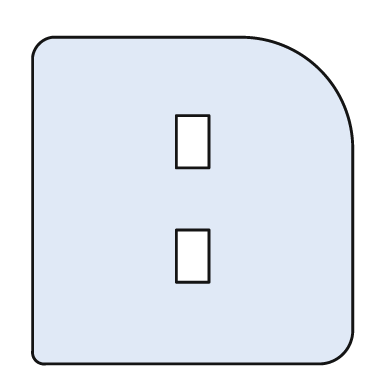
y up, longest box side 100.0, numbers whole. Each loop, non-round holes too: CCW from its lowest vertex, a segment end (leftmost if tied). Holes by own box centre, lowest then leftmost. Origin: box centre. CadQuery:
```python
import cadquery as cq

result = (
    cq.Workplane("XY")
    .moveTo(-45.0, -50.0)
    .lineTo(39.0, -50.0)
    .threePointArc((46.0, -47.0), (49.0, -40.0))
    .lineTo(49.0, 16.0)
    .threePointArc((39.0, 40.0), (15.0, 50.0))
    .lineTo(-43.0, 50.0)
    .threePointArc((-47.0, 48.0), (-49.0, 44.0))
    .lineTo(-49.0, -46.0)
    .threePointArc((-48.0, -49.0), (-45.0, -50.0))
    .close()
    .moveTo(-5.0, -25.0)
    .lineTo(5.0, -25.0)
    .lineTo(5.0, -9.0)
    .lineTo(-5.0, -9.0)
    .close()
    .moveTo(-5.0, 10.0)
    .lineTo(5.0, 10.0)
    .lineTo(5.0, 26.0)
    .lineTo(-5.0, 26.0)
    .close()
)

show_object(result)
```